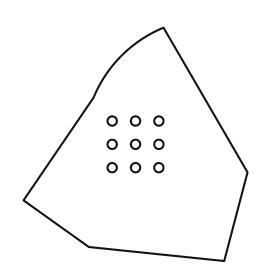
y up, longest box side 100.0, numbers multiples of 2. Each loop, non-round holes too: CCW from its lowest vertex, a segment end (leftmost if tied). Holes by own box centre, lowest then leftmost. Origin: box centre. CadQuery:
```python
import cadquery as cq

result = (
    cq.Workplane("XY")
    .moveTo(38.0, -50.0)
    .lineTo(48.0, -12.0)
    .lineTo(12.0, 50.0)
    .threePointArc((-6.0, 38.0), (-18.0, 20.0))
    .lineTo(-48.0, -24.0)
    .lineTo(-20.0, -44.0)
    .close()
    .moveTo(-10.0, -10.0)
    .circle(2.0)
    .moveTo(0.0, -10.0)
    .circle(2.0)
    .moveTo(10.0, -10.0)
    .circle(2.0)
    .moveTo(-10.0, 0.0)
    .circle(2.0)
    .moveTo(0.0, 0.0)
    .circle(2.0)
    .moveTo(10.0, 0.0)
    .circle(2.0)
    .moveTo(-10.0, 10.0)
    .circle(2.0)
    .moveTo(0.0, 10.0)
    .circle(2.0)
    .moveTo(10.0, 10.0)
    .circle(2.0)
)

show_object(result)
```